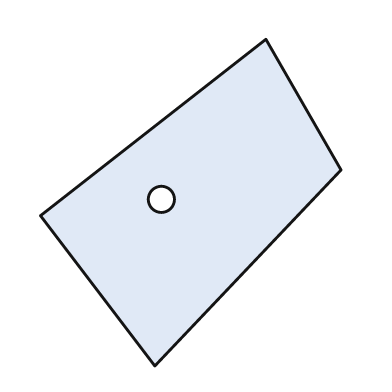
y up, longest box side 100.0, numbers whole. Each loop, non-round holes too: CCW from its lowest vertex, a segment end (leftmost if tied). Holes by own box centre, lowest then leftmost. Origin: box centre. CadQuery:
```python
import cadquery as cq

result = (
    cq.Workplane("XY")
    .moveTo(-11.0, -50.0)
    .lineTo(46.0, 10.0)
    .lineTo(23.0, 50.0)
    .lineTo(-46.0, -4.0)
    .close()
    .moveTo(-9.0, 1.0)
    .circle(4.0)
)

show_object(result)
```